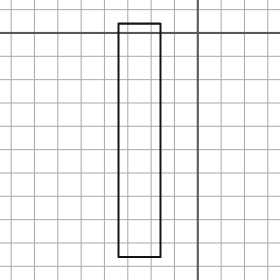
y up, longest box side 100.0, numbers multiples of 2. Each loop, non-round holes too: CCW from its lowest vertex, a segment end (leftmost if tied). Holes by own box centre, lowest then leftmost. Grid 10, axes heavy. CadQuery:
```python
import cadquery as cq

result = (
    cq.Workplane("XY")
    .moveTo(-34.0, -96.0)
    .lineTo(-16.0, -96.0)
    .lineTo(-16.0, 4.0)
    .lineTo(-34.0, 4.0)
    .close()
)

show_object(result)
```